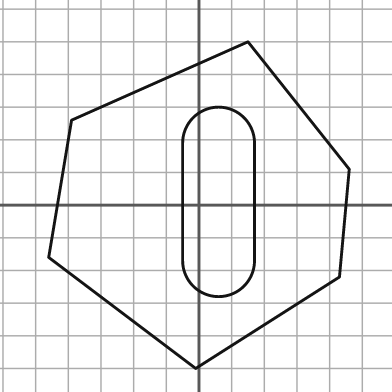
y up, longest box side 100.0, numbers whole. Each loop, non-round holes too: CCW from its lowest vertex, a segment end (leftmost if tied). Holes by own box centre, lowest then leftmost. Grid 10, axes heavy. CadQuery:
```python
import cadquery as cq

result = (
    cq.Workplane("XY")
    .moveTo(-1.0, -50.0)
    .lineTo(43.0, -22.0)
    .lineTo(46.0, 11.0)
    .lineTo(15.0, 50.0)
    .lineTo(-39.0, 26.0)
    .lineTo(-46.0, -16.0)
    .close()
    .moveTo(-5.0, -17.0)
    .threePointArc((6.0, -28.0), (17.0, -17.0))
    .lineTo(17.0, 19.0)
    .threePointArc((6.0, 30.0), (-5.0, 19.0))
    .close()
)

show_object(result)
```